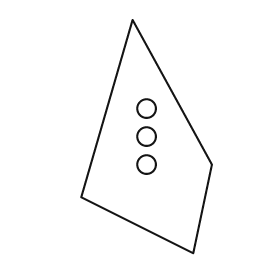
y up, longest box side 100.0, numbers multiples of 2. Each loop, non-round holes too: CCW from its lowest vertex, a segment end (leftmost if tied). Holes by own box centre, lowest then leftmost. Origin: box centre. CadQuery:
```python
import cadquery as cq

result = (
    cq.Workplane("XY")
    .moveTo(20.0, -50.0)
    .lineTo(28.0, -12.0)
    .lineTo(-6.0, 50.0)
    .lineTo(-28.0, -26.0)
    .close()
    .moveTo(0.0, -12.0)
    .circle(4.0)
    .moveTo(0.0, 0.0)
    .circle(4.0)
    .moveTo(0.0, 12.0)
    .circle(4.0)
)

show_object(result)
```